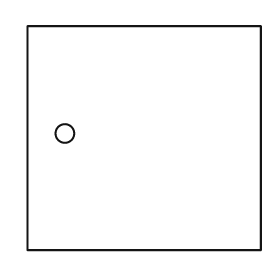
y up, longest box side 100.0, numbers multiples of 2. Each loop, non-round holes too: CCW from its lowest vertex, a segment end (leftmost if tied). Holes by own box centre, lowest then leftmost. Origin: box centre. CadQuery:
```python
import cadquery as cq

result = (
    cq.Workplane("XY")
    .moveTo(-50.0, -48.0)
    .lineTo(50.0, -48.0)
    .lineTo(50.0, 48.0)
    .lineTo(-50.0, 48.0)
    .close()
    .moveTo(-34.0, 2.0)
    .circle(4.0)
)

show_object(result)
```